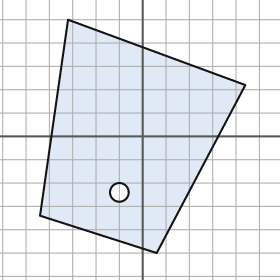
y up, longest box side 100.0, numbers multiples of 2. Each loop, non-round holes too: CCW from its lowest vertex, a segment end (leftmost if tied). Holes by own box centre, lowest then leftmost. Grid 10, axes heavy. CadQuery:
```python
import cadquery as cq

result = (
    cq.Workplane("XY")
    .moveTo(6.0, -50.0)
    .lineTo(44.0, 22.0)
    .lineTo(-32.0, 50.0)
    .lineTo(-44.0, -34.0)
    .close()
    .moveTo(-10.0, -24.0)
    .circle(4.0)
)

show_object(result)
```